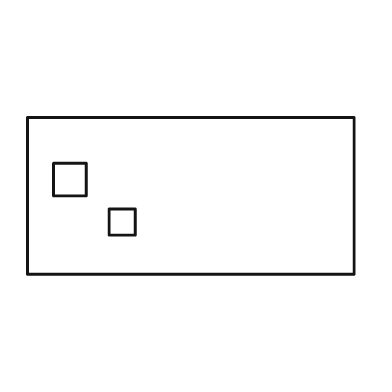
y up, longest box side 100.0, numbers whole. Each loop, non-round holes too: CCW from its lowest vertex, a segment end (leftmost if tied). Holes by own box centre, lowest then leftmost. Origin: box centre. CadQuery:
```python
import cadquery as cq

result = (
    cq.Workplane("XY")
    .moveTo(-50.0, -24.0)
    .lineTo(50.0, -24.0)
    .lineTo(50.0, 24.0)
    .lineTo(-50.0, 24.0)
    .close()
    .moveTo(-25.0, -12.0)
    .lineTo(-17.0, -12.0)
    .lineTo(-17.0, -4.0)
    .lineTo(-25.0, -4.0)
    .close()
    .moveTo(-42.0, 0.0)
    .lineTo(-32.0, 0.0)
    .lineTo(-32.0, 10.0)
    .lineTo(-42.0, 10.0)
    .close()
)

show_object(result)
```